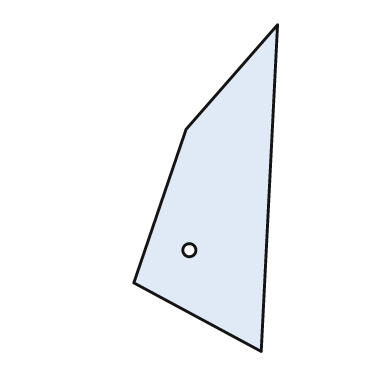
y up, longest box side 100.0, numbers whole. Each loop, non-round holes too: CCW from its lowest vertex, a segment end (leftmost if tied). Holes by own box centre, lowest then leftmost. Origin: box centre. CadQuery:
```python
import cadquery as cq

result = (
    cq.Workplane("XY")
    .moveTo(17.0, -50.0)
    .lineTo(22.0, 50.0)
    .lineTo(-6.0, 18.0)
    .lineTo(-22.0, -29.0)
    .close()
    .moveTo(-5.0, -19.0)
    .circle(2.0)
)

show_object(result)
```